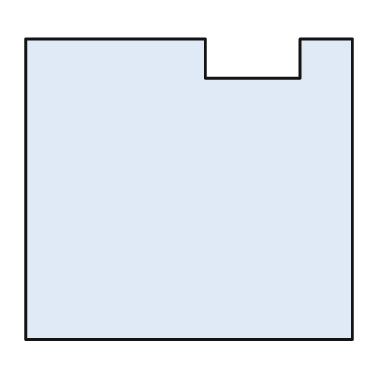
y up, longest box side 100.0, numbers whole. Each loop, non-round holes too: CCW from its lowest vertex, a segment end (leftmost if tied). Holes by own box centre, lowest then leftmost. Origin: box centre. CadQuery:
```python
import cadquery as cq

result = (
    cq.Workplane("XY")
    .moveTo(-50.0, -46.0)
    .lineTo(50.0, -46.0)
    .lineTo(50.0, 46.0)
    .lineTo(34.0, 46.0)
    .lineTo(34.0, 34.0)
    .lineTo(5.0, 34.0)
    .lineTo(5.0, 46.0)
    .lineTo(-50.0, 46.0)
    .close()
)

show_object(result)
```